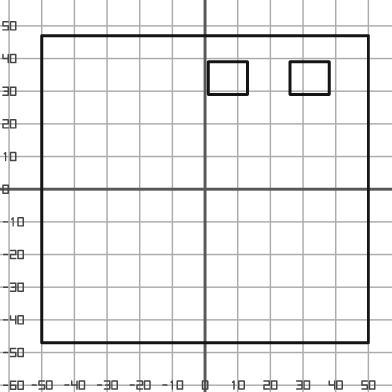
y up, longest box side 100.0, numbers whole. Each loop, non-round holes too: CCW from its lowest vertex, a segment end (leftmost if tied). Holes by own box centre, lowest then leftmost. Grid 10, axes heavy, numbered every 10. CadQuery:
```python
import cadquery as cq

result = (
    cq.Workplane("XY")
    .moveTo(-50.0, -47.0)
    .lineTo(50.0, -47.0)
    .lineTo(50.0, 47.0)
    .lineTo(-50.0, 47.0)
    .close()
    .moveTo(1.0, 29.0)
    .lineTo(13.0, 29.0)
    .lineTo(13.0, 39.0)
    .lineTo(1.0, 39.0)
    .close()
    .moveTo(26.0, 29.0)
    .lineTo(38.0, 29.0)
    .lineTo(38.0, 39.0)
    .lineTo(26.0, 39.0)
    .close()
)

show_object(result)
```